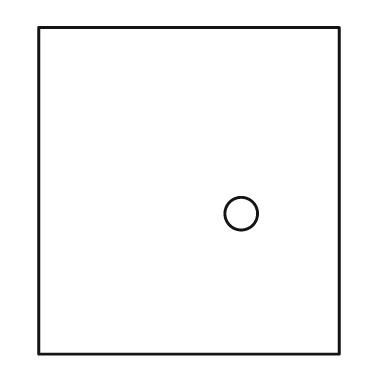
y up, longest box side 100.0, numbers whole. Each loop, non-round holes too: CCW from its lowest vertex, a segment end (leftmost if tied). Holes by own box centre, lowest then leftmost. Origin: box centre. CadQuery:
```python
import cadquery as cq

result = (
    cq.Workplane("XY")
    .moveTo(-46.0, -50.0)
    .lineTo(46.0, -50.0)
    .lineTo(46.0, 50.0)
    .lineTo(-46.0, 50.0)
    .close()
    .moveTo(16.0, -7.0)
    .circle(5.0)
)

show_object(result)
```